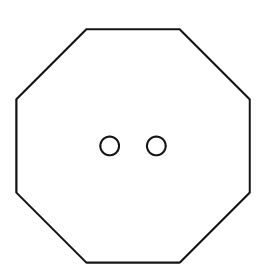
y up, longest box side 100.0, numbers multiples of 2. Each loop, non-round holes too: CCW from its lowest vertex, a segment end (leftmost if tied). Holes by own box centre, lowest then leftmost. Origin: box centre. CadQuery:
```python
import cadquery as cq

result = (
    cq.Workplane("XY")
    .moveTo(-20.0, -50.0)
    .lineTo(20.0, -50.0)
    .lineTo(50.0, -20.0)
    .lineTo(50.0, 20.0)
    .lineTo(20.0, 50.0)
    .lineTo(-20.0, 50.0)
    .lineTo(-50.0, 20.0)
    .lineTo(-50.0, -20.0)
    .close()
    .moveTo(-10.0, 0.0)
    .circle(4.0)
    .moveTo(10.0, 0.0)
    .circle(4.0)
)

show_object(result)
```